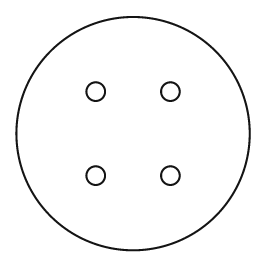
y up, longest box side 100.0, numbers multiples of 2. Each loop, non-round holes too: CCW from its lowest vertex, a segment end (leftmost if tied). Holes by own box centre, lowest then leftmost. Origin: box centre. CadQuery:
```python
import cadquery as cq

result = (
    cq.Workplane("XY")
    .moveTo(0.0, 0.0)
    .circle(50.0)
    .moveTo(-16.0, -18.0)
    .circle(4.0)
    .moveTo(16.0, -18.0)
    .circle(4.0)
    .moveTo(-16.0, 18.0)
    .circle(4.0)
    .moveTo(16.0, 18.0)
    .circle(4.0)
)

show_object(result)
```